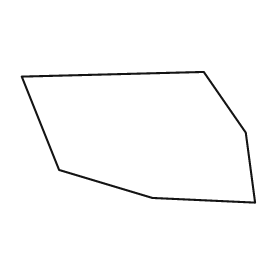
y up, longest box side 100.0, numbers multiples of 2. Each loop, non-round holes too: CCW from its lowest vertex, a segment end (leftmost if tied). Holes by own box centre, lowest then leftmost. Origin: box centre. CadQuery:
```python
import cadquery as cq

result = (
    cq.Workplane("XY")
    .moveTo(50.0, -28.0)
    .lineTo(46.0, 2.0)
    .lineTo(28.0, 28.0)
    .lineTo(-50.0, 26.0)
    .lineTo(-34.0, -14.0)
    .lineTo(6.0, -26.0)
    .close()
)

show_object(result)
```